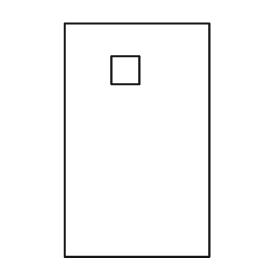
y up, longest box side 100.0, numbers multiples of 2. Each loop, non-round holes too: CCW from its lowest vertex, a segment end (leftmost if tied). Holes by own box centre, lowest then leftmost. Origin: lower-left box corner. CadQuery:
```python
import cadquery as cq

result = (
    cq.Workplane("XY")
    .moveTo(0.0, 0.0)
    .lineTo(62.0, 0.0)
    .lineTo(62.0, 100.0)
    .lineTo(0.0, 100.0)
    .close()
    .moveTo(20.0, 74.0)
    .lineTo(32.0, 74.0)
    .lineTo(32.0, 86.0)
    .lineTo(20.0, 86.0)
    .close()
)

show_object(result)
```